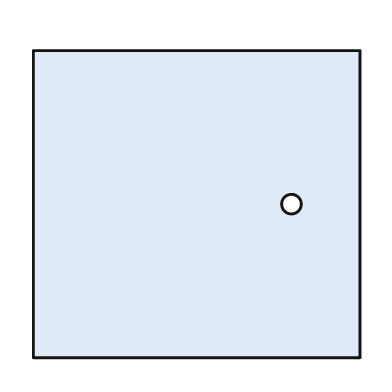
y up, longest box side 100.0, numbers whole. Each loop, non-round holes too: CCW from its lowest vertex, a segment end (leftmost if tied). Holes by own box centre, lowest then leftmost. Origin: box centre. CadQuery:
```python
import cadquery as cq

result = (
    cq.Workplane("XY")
    .moveTo(-50.0, -47.0)
    .lineTo(50.0, -47.0)
    .lineTo(50.0, 47.0)
    .lineTo(-50.0, 47.0)
    .close()
    .moveTo(29.0, 0.0)
    .circle(3.0)
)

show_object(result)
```